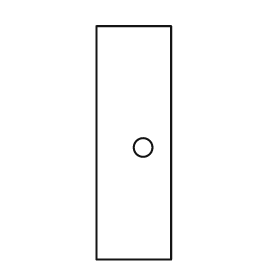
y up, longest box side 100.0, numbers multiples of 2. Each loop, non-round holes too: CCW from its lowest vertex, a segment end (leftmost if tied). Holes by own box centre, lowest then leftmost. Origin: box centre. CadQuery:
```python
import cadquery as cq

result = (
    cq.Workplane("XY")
    .moveTo(-16.0, -50.0)
    .lineTo(16.0, -50.0)
    .lineTo(16.0, 50.0)
    .lineTo(-16.0, 50.0)
    .close()
    .moveTo(4.0, -2.0)
    .circle(4.0)
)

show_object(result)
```